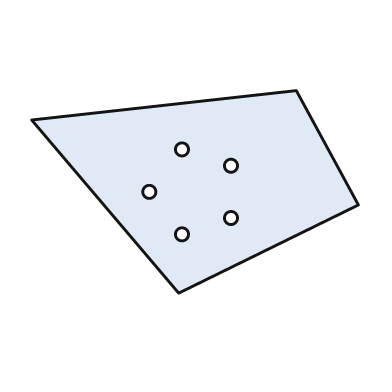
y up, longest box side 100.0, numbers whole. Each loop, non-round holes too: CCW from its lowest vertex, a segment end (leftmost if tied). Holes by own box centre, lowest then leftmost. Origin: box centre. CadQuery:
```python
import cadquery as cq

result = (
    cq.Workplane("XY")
    .moveTo(-5.0, -31.0)
    .lineTo(50.0, -4.0)
    .lineTo(31.0, 31.0)
    .lineTo(-50.0, 22.0)
    .close()
    .moveTo(-4.0, -13.0)
    .circle(2.0)
    .moveTo(11.0, -8.0)
    .circle(2.0)
    .moveTo(-14.0, 0.0)
    .circle(2.0)
    .moveTo(11.0, 8.0)
    .circle(2.0)
    .moveTo(-4.0, 13.0)
    .circle(2.0)
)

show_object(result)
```